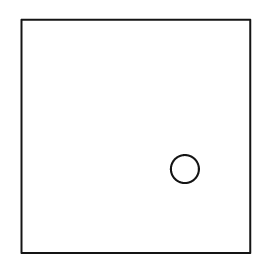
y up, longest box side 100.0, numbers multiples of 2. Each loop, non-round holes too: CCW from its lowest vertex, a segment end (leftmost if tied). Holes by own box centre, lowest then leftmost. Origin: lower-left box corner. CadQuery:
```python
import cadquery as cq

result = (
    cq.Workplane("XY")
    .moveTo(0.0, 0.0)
    .lineTo(98.0, 0.0)
    .lineTo(98.0, 100.0)
    .lineTo(0.0, 100.0)
    .close()
    .moveTo(70.0, 36.0)
    .circle(6.0)
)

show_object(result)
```